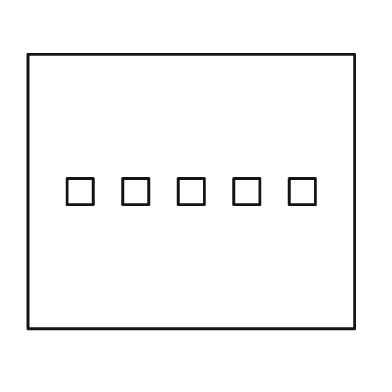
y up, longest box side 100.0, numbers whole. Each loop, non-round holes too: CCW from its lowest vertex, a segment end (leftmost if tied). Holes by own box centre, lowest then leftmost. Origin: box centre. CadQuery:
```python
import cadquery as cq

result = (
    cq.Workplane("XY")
    .moveTo(-50.0, -42.0)
    .lineTo(50.0, -42.0)
    .lineTo(50.0, 42.0)
    .lineTo(-50.0, 42.0)
    .close()
    .moveTo(-38.0, -4.0)
    .lineTo(-30.0, -4.0)
    .lineTo(-30.0, 4.0)
    .lineTo(-38.0, 4.0)
    .close()
    .moveTo(-21.0, -4.0)
    .lineTo(-13.0, -4.0)
    .lineTo(-13.0, 4.0)
    .lineTo(-21.0, 4.0)
    .close()
    .moveTo(-4.0, -4.0)
    .lineTo(4.0, -4.0)
    .lineTo(4.0, 4.0)
    .lineTo(-4.0, 4.0)
    .close()
    .moveTo(13.0, -4.0)
    .lineTo(21.0, -4.0)
    .lineTo(21.0, 4.0)
    .lineTo(13.0, 4.0)
    .close()
    .moveTo(30.0, -4.0)
    .lineTo(38.0, -4.0)
    .lineTo(38.0, 4.0)
    .lineTo(30.0, 4.0)
    .close()
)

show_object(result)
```